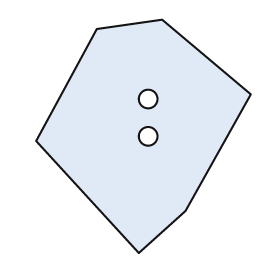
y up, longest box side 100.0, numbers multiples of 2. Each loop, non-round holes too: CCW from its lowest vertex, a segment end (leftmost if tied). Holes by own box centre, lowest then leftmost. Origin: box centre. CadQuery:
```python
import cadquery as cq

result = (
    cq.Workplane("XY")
    .moveTo(-2.0, -50.0)
    .lineTo(18.0, -32.0)
    .lineTo(46.0, 18.0)
    .lineTo(8.0, 50.0)
    .lineTo(-20.0, 46.0)
    .lineTo(-46.0, -2.0)
    .close()
    .moveTo(2.0, 0.0)
    .circle(4.0)
    .moveTo(2.0, 16.0)
    .circle(4.0)
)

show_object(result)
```